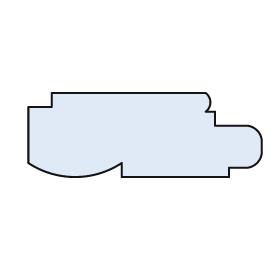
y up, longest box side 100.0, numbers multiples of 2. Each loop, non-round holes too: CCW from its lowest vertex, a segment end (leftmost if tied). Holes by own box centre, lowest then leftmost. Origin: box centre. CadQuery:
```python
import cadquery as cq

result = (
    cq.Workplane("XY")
    .moveTo(-10.0, -18.0)
    .lineTo(36.0, -18.0)
    .lineTo(36.0, -14.0)
    .lineTo(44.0, -14.0)
    .threePointArc((48.0, -12.0), (50.0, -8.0))
    .lineTo(50.0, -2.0)
    .threePointArc((48.0, 2.0), (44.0, 4.0))
    .lineTo(30.0, 4.0)
    .lineTo(30.0, 10.0)
    .lineTo(26.0, 10.0)
    .threePointArc((28.0, 14.0), (26.0, 18.0))
    .lineTo(-40.0, 18.0)
    .lineTo(-40.0, 12.0)
    .lineTo(-50.0, 12.0)
    .lineTo(-50.0, -12.0)
    .threePointArc((-30.0, -18.0), (-10.0, -12.0))
    .close()
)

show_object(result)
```